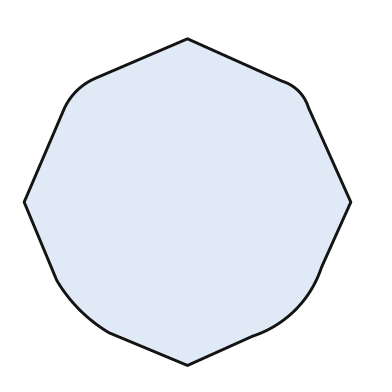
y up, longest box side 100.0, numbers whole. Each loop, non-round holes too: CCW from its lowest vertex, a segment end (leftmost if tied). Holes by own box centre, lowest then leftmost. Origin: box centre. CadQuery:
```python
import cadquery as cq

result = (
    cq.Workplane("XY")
    .moveTo(0.0, -50.0)
    .lineTo(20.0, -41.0)
    .threePointArc((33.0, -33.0), (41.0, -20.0))
    .lineTo(50.0, 0.0)
    .lineTo(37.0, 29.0)
    .threePointArc((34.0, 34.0), (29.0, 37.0))
    .lineTo(0.0, 50.0)
    .lineTo(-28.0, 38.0)
    .threePointArc((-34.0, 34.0), (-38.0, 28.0))
    .lineTo(-50.0, 0.0)
    .lineTo(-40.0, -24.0)
    .threePointArc((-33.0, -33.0), (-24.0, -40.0))
    .close()
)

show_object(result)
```